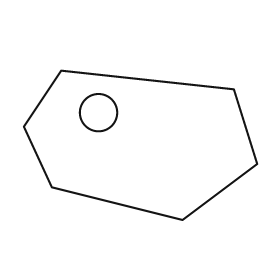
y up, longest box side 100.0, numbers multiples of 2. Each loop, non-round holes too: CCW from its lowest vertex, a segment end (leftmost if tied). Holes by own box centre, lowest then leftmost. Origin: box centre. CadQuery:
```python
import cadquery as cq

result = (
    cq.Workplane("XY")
    .moveTo(18.0, -32.0)
    .lineTo(50.0, -8.0)
    .lineTo(40.0, 24.0)
    .lineTo(-34.0, 32.0)
    .lineTo(-50.0, 8.0)
    .lineTo(-38.0, -18.0)
    .close()
    .moveTo(-18.0, 14.0)
    .circle(8.0)
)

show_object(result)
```